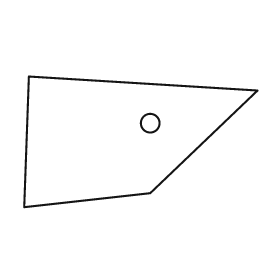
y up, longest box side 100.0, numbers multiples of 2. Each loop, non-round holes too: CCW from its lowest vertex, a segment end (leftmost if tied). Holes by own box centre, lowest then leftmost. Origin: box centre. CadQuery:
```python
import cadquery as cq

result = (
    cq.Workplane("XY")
    .moveTo(-50.0, -28.0)
    .lineTo(4.0, -22.0)
    .lineTo(50.0, 22.0)
    .lineTo(-48.0, 28.0)
    .close()
    .moveTo(4.0, 8.0)
    .circle(4.0)
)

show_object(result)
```